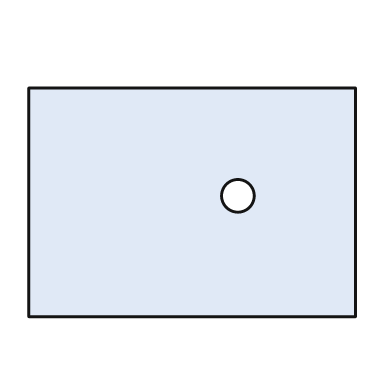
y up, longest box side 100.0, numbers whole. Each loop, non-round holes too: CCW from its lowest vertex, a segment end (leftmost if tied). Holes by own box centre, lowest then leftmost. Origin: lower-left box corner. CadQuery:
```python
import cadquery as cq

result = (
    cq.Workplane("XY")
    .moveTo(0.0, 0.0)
    .lineTo(100.0, 0.0)
    .lineTo(100.0, 70.0)
    .lineTo(0.0, 70.0)
    .close()
    .moveTo(64.0, 37.0)
    .circle(5.0)
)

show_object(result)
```